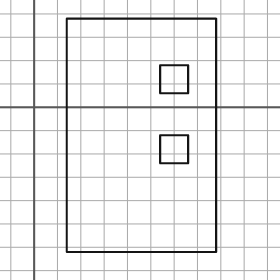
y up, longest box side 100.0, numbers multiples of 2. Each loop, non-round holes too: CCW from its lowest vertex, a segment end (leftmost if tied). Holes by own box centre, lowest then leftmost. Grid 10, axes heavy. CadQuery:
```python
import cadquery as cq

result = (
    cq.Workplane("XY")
    .moveTo(14.0, -62.0)
    .lineTo(78.0, -62.0)
    .lineTo(78.0, 38.0)
    .lineTo(14.0, 38.0)
    .close()
    .moveTo(54.0, -24.0)
    .lineTo(66.0, -24.0)
    .lineTo(66.0, -12.0)
    .lineTo(54.0, -12.0)
    .close()
    .moveTo(54.0, 6.0)
    .lineTo(66.0, 6.0)
    .lineTo(66.0, 18.0)
    .lineTo(54.0, 18.0)
    .close()
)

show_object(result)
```